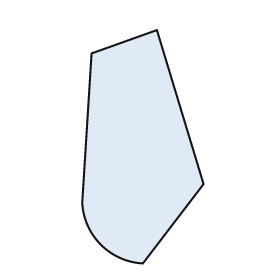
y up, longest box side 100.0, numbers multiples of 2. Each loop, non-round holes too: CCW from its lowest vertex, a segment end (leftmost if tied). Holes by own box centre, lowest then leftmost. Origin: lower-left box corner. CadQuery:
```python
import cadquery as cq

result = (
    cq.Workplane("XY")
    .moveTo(26.0, 0.0)
    .lineTo(52.0, 34.0)
    .lineTo(32.0, 100.0)
    .lineTo(4.0, 90.0)
    .lineTo(0.0, 26.0)
    .threePointArc((8.0, 8.0), (26.0, 0.0))
    .close()
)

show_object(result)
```